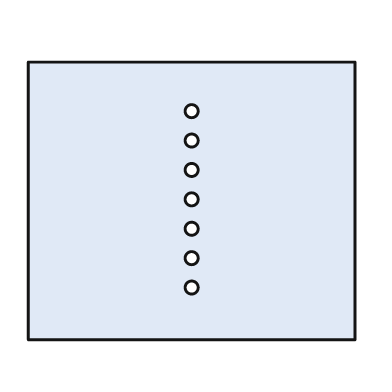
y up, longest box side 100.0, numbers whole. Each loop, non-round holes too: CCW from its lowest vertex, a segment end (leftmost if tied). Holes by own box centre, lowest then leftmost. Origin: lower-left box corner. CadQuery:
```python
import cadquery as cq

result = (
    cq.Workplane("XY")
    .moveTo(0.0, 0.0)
    .lineTo(100.0, 0.0)
    .lineTo(100.0, 85.0)
    .lineTo(0.0, 85.0)
    .close()
    .moveTo(50.0, 16.0)
    .circle(2.0)
    .moveTo(50.0, 25.0)
    .circle(2.0)
    .moveTo(50.0, 34.0)
    .circle(2.0)
    .moveTo(50.0, 43.0)
    .circle(2.0)
    .moveTo(50.0, 52.0)
    .circle(2.0)
    .moveTo(50.0, 61.0)
    .circle(2.0)
    .moveTo(50.0, 70.0)
    .circle(2.0)
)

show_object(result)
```